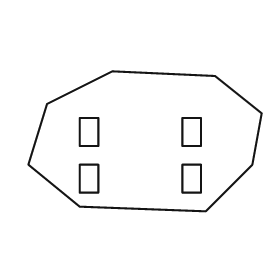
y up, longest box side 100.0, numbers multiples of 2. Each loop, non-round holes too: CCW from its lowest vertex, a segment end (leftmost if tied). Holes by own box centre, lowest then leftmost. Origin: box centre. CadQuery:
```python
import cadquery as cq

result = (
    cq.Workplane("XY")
    .moveTo(26.0, -30.0)
    .lineTo(46.0, -10.0)
    .lineTo(50.0, 12.0)
    .lineTo(30.0, 28.0)
    .lineTo(-14.0, 30.0)
    .lineTo(-42.0, 16.0)
    .lineTo(-50.0, -10.0)
    .lineTo(-28.0, -28.0)
    .close()
    .moveTo(-28.0, -22.0)
    .lineTo(-20.0, -22.0)
    .lineTo(-20.0, -10.0)
    .lineTo(-28.0, -10.0)
    .close()
    .moveTo(16.0, -22.0)
    .lineTo(24.0, -22.0)
    .lineTo(24.0, -10.0)
    .lineTo(16.0, -10.0)
    .close()
    .moveTo(-28.0, -2.0)
    .lineTo(-20.0, -2.0)
    .lineTo(-20.0, 10.0)
    .lineTo(-28.0, 10.0)
    .close()
    .moveTo(16.0, -2.0)
    .lineTo(24.0, -2.0)
    .lineTo(24.0, 10.0)
    .lineTo(16.0, 10.0)
    .close()
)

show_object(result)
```